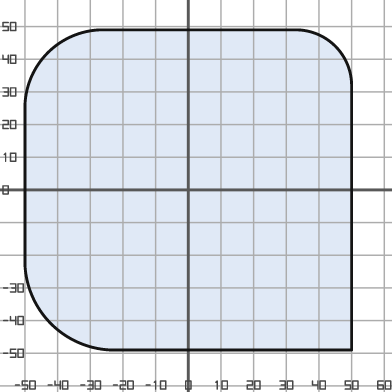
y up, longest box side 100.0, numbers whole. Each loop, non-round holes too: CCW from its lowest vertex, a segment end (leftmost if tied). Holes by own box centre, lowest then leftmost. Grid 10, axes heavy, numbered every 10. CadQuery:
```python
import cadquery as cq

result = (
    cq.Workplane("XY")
    .moveTo(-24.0, -49.0)
    .lineTo(50.0, -49.0)
    .lineTo(50.0, 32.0)
    .threePointArc((45.0, 44.0), (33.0, 49.0))
    .lineTo(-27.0, 49.0)
    .threePointArc((-43.0, 42.0), (-50.0, 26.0))
    .lineTo(-50.0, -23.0)
    .threePointArc((-42.0, -41.0), (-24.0, -49.0))
    .close()
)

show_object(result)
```